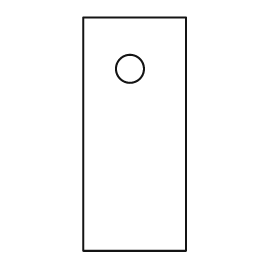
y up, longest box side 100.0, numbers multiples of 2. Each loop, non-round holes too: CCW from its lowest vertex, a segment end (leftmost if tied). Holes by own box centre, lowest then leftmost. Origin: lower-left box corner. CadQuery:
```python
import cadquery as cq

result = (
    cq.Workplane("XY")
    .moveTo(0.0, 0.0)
    .lineTo(44.0, 0.0)
    .lineTo(44.0, 100.0)
    .lineTo(0.0, 100.0)
    .close()
    .moveTo(20.0, 78.0)
    .circle(6.0)
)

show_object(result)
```